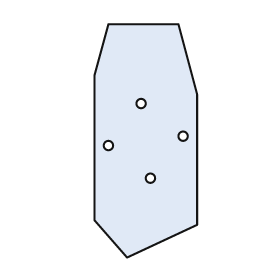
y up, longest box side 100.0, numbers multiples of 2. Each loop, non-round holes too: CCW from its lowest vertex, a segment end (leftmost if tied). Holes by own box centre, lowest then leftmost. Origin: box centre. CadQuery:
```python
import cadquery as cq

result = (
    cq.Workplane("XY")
    .moveTo(-8.0, -50.0)
    .lineTo(22.0, -36.0)
    .lineTo(22.0, 20.0)
    .lineTo(14.0, 50.0)
    .lineTo(-16.0, 50.0)
    .lineTo(-22.0, 28.0)
    .lineTo(-22.0, -34.0)
    .close()
    .moveTo(2.0, -16.0)
    .circle(2.0)
    .moveTo(-16.0, -2.0)
    .circle(2.0)
    .moveTo(16.0, 2.0)
    .circle(2.0)
    .moveTo(-2.0, 16.0)
    .circle(2.0)
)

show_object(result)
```